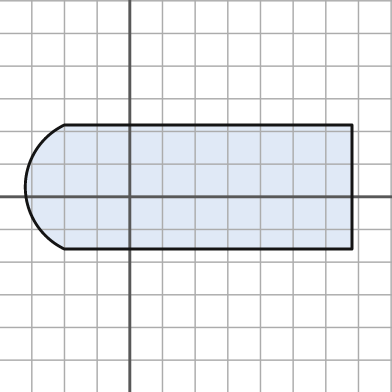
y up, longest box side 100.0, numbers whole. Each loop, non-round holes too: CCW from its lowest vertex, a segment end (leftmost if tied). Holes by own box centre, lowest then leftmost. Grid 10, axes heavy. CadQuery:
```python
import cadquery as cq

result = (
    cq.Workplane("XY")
    .moveTo(-20.0, -16.0)
    .lineTo(68.0, -16.0)
    .lineTo(68.0, 22.0)
    .lineTo(-20.0, 22.0)
    .threePointArc((-32.0, 3.0), (-20.0, -16.0))
    .close()
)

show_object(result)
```